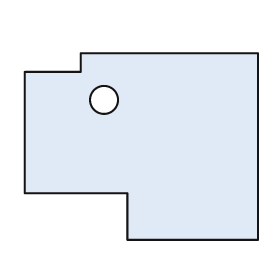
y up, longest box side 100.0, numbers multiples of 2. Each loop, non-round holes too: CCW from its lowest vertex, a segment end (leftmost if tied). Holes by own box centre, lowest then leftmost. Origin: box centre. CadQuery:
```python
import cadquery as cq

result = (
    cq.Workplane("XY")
    .moveTo(-6.0, -40.0)
    .lineTo(50.0, -40.0)
    .lineTo(50.0, 40.0)
    .lineTo(-26.0, 40.0)
    .lineTo(-26.0, 32.0)
    .lineTo(-50.0, 32.0)
    .lineTo(-50.0, -20.0)
    .lineTo(-6.0, -20.0)
    .close()
    .moveTo(-16.0, 20.0)
    .circle(6.0)
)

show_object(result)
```